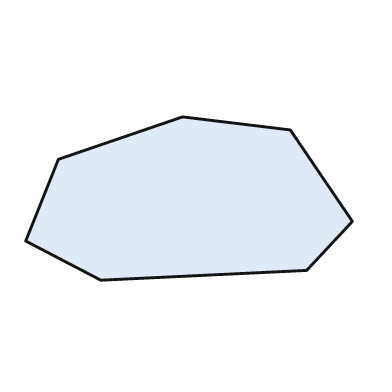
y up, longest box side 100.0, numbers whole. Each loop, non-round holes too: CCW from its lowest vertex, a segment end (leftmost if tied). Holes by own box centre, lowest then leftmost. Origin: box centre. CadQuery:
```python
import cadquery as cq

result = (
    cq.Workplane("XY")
    .moveTo(-27.0, -25.0)
    .lineTo(36.0, -22.0)
    .lineTo(50.0, -7.0)
    .lineTo(31.0, 21.0)
    .lineTo(-2.0, 25.0)
    .lineTo(-40.0, 12.0)
    .lineTo(-50.0, -13.0)
    .close()
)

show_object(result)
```